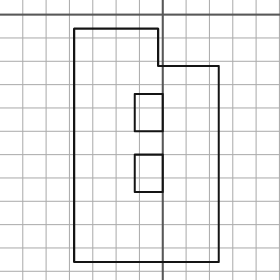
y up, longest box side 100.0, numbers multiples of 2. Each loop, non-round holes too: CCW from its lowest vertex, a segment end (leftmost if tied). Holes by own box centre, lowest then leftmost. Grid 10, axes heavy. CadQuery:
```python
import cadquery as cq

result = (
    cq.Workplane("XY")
    .moveTo(-38.0, -106.0)
    .lineTo(24.0, -106.0)
    .lineTo(24.0, -22.0)
    .lineTo(-2.0, -22.0)
    .lineTo(-2.0, -6.0)
    .lineTo(-38.0, -6.0)
    .close()
    .moveTo(-12.0, -76.0)
    .lineTo(0.0, -76.0)
    .lineTo(0.0, -60.0)
    .lineTo(-12.0, -60.0)
    .close()
    .moveTo(-12.0, -50.0)
    .lineTo(0.0, -50.0)
    .lineTo(0.0, -34.0)
    .lineTo(-12.0, -34.0)
    .close()
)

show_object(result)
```